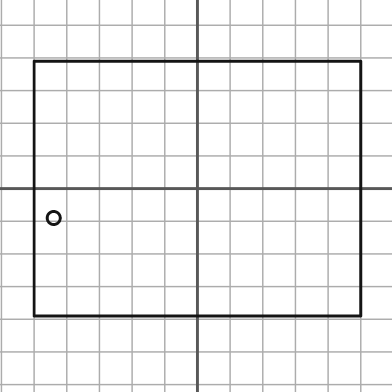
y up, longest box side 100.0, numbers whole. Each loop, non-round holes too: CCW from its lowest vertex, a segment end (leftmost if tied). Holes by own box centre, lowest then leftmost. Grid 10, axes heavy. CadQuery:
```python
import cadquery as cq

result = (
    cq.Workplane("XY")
    .moveTo(-50.0, -39.0)
    .lineTo(50.0, -39.0)
    .lineTo(50.0, 39.0)
    .lineTo(-50.0, 39.0)
    .close()
    .moveTo(-44.0, -9.0)
    .circle(2.0)
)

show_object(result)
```